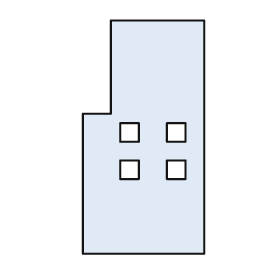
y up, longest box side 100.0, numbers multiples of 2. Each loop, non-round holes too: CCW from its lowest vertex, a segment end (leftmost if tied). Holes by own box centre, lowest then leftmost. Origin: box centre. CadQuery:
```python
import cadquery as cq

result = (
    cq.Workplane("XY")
    .moveTo(-26.0, -50.0)
    .lineTo(26.0, -50.0)
    .lineTo(26.0, 50.0)
    .lineTo(-14.0, 50.0)
    .lineTo(-14.0, 10.0)
    .lineTo(-26.0, 10.0)
    .close()
    .moveTo(-10.0, -18.0)
    .lineTo(-2.0, -18.0)
    .lineTo(-2.0, -10.0)
    .lineTo(-10.0, -10.0)
    .close()
    .moveTo(10.0, -18.0)
    .lineTo(18.0, -18.0)
    .lineTo(18.0, -10.0)
    .lineTo(10.0, -10.0)
    .close()
    .moveTo(-10.0, -2.0)
    .lineTo(-2.0, -2.0)
    .lineTo(-2.0, 6.0)
    .lineTo(-10.0, 6.0)
    .close()
    .moveTo(10.0, -2.0)
    .lineTo(18.0, -2.0)
    .lineTo(18.0, 6.0)
    .lineTo(10.0, 6.0)
    .close()
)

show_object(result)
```